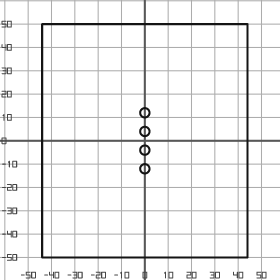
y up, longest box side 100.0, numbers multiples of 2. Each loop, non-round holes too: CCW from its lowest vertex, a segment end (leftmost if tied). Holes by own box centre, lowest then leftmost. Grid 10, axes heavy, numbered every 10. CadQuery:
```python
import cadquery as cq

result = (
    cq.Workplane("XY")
    .moveTo(-44.0, -50.0)
    .lineTo(44.0, -50.0)
    .lineTo(44.0, 50.0)
    .lineTo(-44.0, 50.0)
    .close()
    .moveTo(0.0, -12.0)
    .circle(2.0)
    .moveTo(0.0, -4.0)
    .circle(2.0)
    .moveTo(0.0, 4.0)
    .circle(2.0)
    .moveTo(0.0, 12.0)
    .circle(2.0)
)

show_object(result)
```